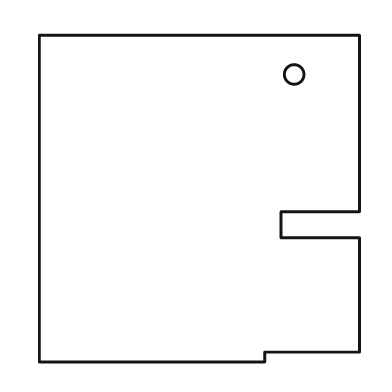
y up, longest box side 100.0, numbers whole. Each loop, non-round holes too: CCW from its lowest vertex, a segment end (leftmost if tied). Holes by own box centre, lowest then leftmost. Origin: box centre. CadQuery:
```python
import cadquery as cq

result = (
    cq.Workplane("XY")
    .moveTo(-49.0, -50.0)
    .lineTo(20.0, -50.0)
    .lineTo(20.0, -47.0)
    .lineTo(49.0, -47.0)
    .lineTo(49.0, -12.0)
    .lineTo(25.0, -12.0)
    .lineTo(25.0, -4.0)
    .lineTo(49.0, -4.0)
    .lineTo(49.0, 50.0)
    .lineTo(-49.0, 50.0)
    .close()
    .moveTo(29.0, 38.0)
    .circle(3.0)
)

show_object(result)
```